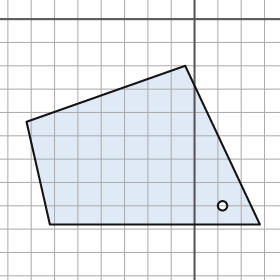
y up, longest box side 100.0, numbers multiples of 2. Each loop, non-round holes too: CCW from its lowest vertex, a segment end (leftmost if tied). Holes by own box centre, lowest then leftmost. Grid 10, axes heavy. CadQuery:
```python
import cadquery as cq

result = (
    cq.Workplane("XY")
    .moveTo(-62.0, -88.0)
    .lineTo(28.0, -88.0)
    .lineTo(-4.0, -20.0)
    .lineTo(-72.0, -44.0)
    .close()
    .moveTo(12.0, -80.0)
    .circle(2.0)
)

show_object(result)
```